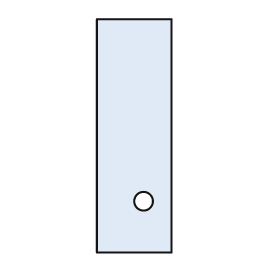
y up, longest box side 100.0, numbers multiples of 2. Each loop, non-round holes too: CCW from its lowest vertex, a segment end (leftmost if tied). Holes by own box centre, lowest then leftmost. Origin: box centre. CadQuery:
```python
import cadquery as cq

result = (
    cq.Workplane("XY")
    .moveTo(-16.0, -50.0)
    .lineTo(16.0, -50.0)
    .lineTo(16.0, 50.0)
    .lineTo(-16.0, 50.0)
    .close()
    .moveTo(4.0, -28.0)
    .circle(4.0)
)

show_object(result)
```